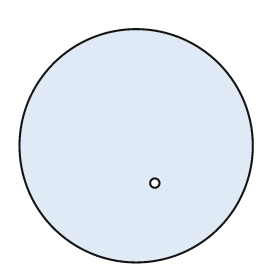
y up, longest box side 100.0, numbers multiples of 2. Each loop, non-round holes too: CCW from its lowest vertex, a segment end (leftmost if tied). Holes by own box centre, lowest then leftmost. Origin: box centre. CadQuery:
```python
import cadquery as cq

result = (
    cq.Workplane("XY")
    .moveTo(0.0, 0.0)
    .circle(50.0)
    .moveTo(8.0, -16.0)
    .circle(2.0)
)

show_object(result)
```